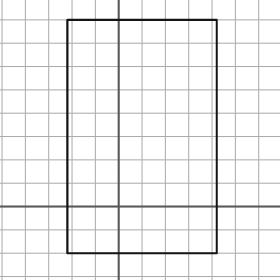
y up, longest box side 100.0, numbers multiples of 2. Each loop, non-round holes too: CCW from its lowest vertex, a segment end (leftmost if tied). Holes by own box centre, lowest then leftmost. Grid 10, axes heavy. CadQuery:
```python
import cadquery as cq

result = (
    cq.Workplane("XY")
    .moveTo(-22.0, -20.0)
    .lineTo(42.0, -20.0)
    .lineTo(42.0, 80.0)
    .lineTo(-22.0, 80.0)
    .close()
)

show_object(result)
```